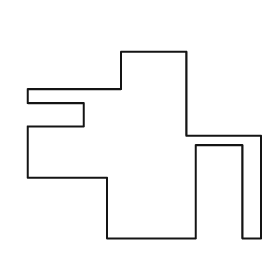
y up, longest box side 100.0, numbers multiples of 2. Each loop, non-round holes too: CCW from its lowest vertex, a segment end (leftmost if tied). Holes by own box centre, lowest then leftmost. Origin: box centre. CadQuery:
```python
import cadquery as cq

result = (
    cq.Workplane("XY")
    .moveTo(-16.0, -40.0)
    .lineTo(22.0, -40.0)
    .lineTo(22.0, 0.0)
    .lineTo(42.0, 0.0)
    .lineTo(42.0, -40.0)
    .lineTo(50.0, -40.0)
    .lineTo(50.0, 4.0)
    .lineTo(18.0, 4.0)
    .lineTo(18.0, 40.0)
    .lineTo(-10.0, 40.0)
    .lineTo(-10.0, 24.0)
    .lineTo(-50.0, 24.0)
    .lineTo(-50.0, 18.0)
    .lineTo(-26.0, 18.0)
    .lineTo(-26.0, 8.0)
    .lineTo(-50.0, 8.0)
    .lineTo(-50.0, -14.0)
    .lineTo(-16.0, -14.0)
    .close()
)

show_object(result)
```